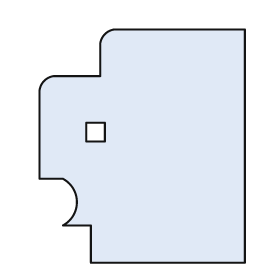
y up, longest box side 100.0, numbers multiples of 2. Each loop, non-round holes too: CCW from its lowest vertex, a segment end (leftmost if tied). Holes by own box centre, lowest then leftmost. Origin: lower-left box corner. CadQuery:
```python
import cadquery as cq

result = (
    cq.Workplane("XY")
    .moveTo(22.0, 0.0)
    .lineTo(88.0, 0.0)
    .lineTo(88.0, 100.0)
    .lineTo(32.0, 100.0)
    .threePointArc((28.0, 98.0), (26.0, 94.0))
    .lineTo(26.0, 80.0)
    .lineTo(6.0, 80.0)
    .threePointArc((2.0, 78.0), (0.0, 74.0))
    .lineTo(0.0, 36.0)
    .lineTo(10.0, 36.0)
    .threePointArc((16.0, 26.0), (10.0, 16.0))
    .lineTo(22.0, 16.0)
    .close()
    .moveTo(20.0, 52.0)
    .lineTo(28.0, 52.0)
    .lineTo(28.0, 60.0)
    .lineTo(20.0, 60.0)
    .close()
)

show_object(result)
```